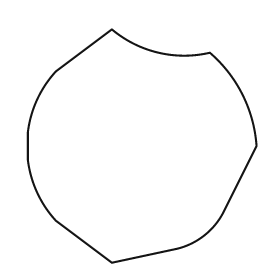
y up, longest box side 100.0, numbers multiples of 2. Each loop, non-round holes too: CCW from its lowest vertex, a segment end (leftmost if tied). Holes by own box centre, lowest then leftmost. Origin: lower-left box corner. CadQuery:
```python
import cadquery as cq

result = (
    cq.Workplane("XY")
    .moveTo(36.0, 0.0)
    .lineTo(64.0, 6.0)
    .threePointArc((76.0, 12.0), (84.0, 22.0))
    .lineTo(98.0, 50.0)
    .threePointArc((92.0, 72.0), (78.0, 90.0))
    .threePointArc((56.0, 90.0), (36.0, 100.0))
    .lineTo(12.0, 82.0)
    .threePointArc((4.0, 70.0), (0.0, 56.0))
    .lineTo(0.0, 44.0)
    .threePointArc((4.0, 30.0), (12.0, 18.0))
    .close()
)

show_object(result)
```